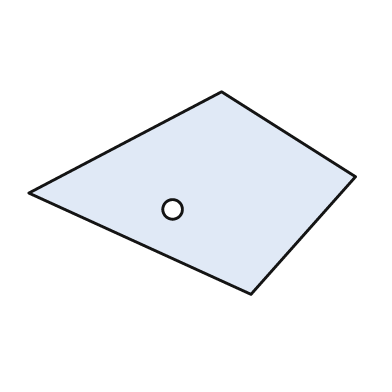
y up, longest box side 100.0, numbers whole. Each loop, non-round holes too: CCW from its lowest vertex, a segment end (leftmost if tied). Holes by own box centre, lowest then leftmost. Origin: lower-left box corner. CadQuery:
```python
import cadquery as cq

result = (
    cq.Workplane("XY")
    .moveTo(68.0, 0.0)
    .lineTo(100.0, 36.0)
    .lineTo(59.0, 62.0)
    .lineTo(0.0, 31.0)
    .close()
    .moveTo(44.0, 26.0)
    .circle(3.0)
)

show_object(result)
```